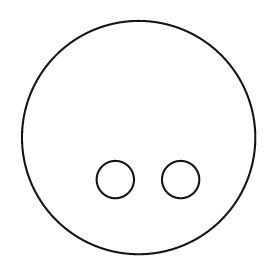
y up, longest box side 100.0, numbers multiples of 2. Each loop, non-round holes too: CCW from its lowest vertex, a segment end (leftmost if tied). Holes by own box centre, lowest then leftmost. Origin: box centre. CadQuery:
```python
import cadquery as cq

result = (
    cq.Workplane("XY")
    .moveTo(0.0, 0.0)
    .circle(50.0)
    .moveTo(-10.0, -18.0)
    .circle(8.0)
    .moveTo(18.0, -18.0)
    .circle(8.0)
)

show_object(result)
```